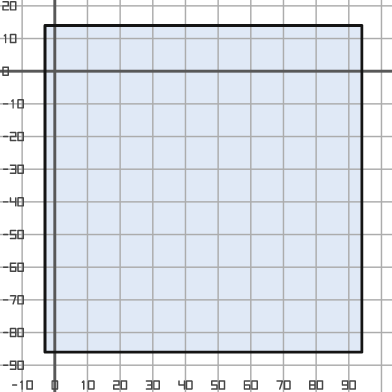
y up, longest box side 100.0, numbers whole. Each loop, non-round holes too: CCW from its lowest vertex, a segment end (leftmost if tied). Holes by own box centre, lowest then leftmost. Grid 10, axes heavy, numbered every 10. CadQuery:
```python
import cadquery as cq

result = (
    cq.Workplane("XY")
    .moveTo(-3.0, -86.0)
    .lineTo(94.0, -86.0)
    .lineTo(94.0, 14.0)
    .lineTo(-3.0, 14.0)
    .close()
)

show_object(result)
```